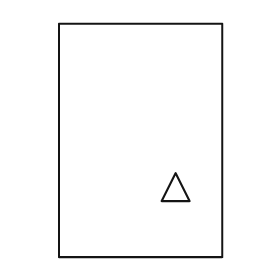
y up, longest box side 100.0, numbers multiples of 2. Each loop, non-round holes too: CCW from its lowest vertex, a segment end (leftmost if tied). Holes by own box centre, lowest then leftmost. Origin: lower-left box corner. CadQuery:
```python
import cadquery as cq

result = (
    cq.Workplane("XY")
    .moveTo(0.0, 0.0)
    .lineTo(70.0, 0.0)
    .lineTo(70.0, 100.0)
    .lineTo(0.0, 100.0)
    .close()
    .moveTo(44.0, 24.0)
    .lineTo(56.0, 24.0)
    .lineTo(50.0, 36.0)
    .close()
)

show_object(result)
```